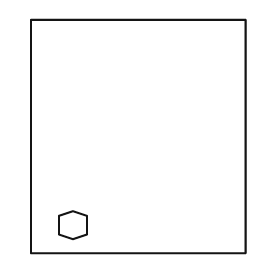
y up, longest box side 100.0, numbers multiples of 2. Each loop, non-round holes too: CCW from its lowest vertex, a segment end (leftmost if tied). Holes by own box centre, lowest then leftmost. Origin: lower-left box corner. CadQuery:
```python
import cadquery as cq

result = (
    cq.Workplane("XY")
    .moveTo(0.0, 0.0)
    .lineTo(92.0, 0.0)
    .lineTo(92.0, 100.0)
    .lineTo(0.0, 100.0)
    .close()
    .moveTo(18.0, 6.0)
    .lineTo(24.0, 8.0)
    .lineTo(24.0, 16.0)
    .lineTo(18.0, 18.0)
    .lineTo(12.0, 16.0)
    .lineTo(12.0, 8.0)
    .close()
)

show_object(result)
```